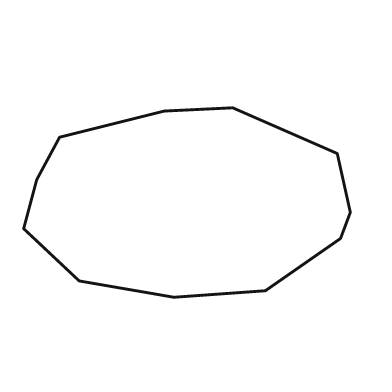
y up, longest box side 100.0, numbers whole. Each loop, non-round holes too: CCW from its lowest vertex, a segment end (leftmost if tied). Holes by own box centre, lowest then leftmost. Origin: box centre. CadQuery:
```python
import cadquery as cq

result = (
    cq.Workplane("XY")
    .moveTo(-4.0, -29.0)
    .lineTo(24.0, -27.0)
    .lineTo(47.0, -11.0)
    .lineTo(50.0, -3.0)
    .lineTo(46.0, 15.0)
    .lineTo(14.0, 29.0)
    .lineTo(-7.0, 28.0)
    .lineTo(-39.0, 20.0)
    .lineTo(-46.0, 7.0)
    .lineTo(-50.0, -8.0)
    .lineTo(-33.0, -24.0)
    .close()
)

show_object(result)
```